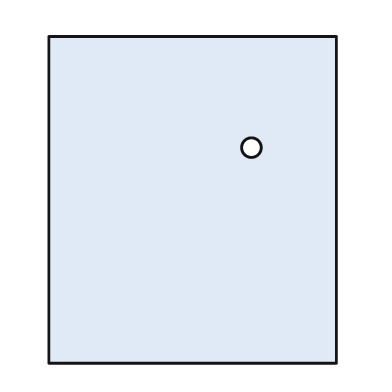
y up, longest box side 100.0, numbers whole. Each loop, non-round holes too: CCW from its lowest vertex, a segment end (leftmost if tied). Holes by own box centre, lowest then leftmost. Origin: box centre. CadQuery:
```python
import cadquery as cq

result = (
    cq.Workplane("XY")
    .moveTo(-44.0, -50.0)
    .lineTo(44.0, -50.0)
    .lineTo(44.0, 50.0)
    .lineTo(-44.0, 50.0)
    .close()
    .moveTo(18.0, 16.0)
    .circle(3.0)
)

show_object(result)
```